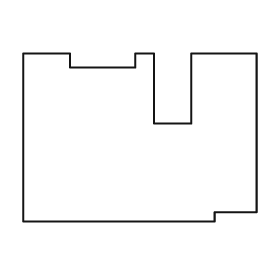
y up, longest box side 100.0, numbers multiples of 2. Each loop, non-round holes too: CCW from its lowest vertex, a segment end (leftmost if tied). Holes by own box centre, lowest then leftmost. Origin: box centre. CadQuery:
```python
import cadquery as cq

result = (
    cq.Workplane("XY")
    .moveTo(-50.0, -36.0)
    .lineTo(32.0, -36.0)
    .lineTo(32.0, -32.0)
    .lineTo(50.0, -32.0)
    .lineTo(50.0, 36.0)
    .lineTo(22.0, 36.0)
    .lineTo(22.0, 6.0)
    .lineTo(6.0, 6.0)
    .lineTo(6.0, 36.0)
    .lineTo(-2.0, 36.0)
    .lineTo(-2.0, 30.0)
    .lineTo(-30.0, 30.0)
    .lineTo(-30.0, 36.0)
    .lineTo(-50.0, 36.0)
    .close()
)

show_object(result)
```